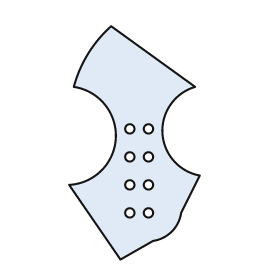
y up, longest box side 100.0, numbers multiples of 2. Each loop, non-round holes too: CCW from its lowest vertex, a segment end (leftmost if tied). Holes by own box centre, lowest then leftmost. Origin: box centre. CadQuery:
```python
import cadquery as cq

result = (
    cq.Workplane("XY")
    .moveTo(-6.0, -50.0)
    .lineTo(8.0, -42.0)
    .threePointArc((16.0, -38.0), (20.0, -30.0))
    .lineTo(28.0, -14.0)
    .threePointArc((12.0, 4.0), (26.0, 24.0))
    .lineTo(-10.0, 50.0)
    .threePointArc((-20.0, 38.0), (-26.0, 24.0))
    .threePointArc((-8.0, 2.0), (-28.0, -18.0))
    .close()
    .moveTo(-2.0, -30.0)
    .circle(2.0)
    .moveTo(6.0, -30.0)
    .circle(2.0)
    .moveTo(-2.0, -18.0)
    .circle(2.0)
    .moveTo(6.0, -18.0)
    .circle(2.0)
    .moveTo(-2.0, -6.0)
    .circle(2.0)
    .moveTo(6.0, -6.0)
    .circle(2.0)
    .moveTo(-2.0, 6.0)
    .circle(2.0)
    .moveTo(6.0, 6.0)
    .circle(2.0)
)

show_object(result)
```